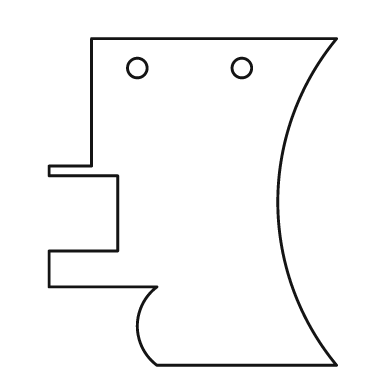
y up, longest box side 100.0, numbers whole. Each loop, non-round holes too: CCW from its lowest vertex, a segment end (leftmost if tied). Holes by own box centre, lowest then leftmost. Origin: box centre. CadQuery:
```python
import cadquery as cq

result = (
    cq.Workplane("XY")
    .moveTo(-11.0, -50.0)
    .lineTo(44.0, -50.0)
    .threePointArc((26.0, 0.0), (44.0, 50.0))
    .lineTo(-31.0, 50.0)
    .lineTo(-31.0, 11.0)
    .lineTo(-44.0, 11.0)
    .lineTo(-44.0, 8.0)
    .lineTo(-23.0, 8.0)
    .lineTo(-23.0, -15.0)
    .lineTo(-44.0, -15.0)
    .lineTo(-44.0, -26.0)
    .lineTo(-11.0, -26.0)
    .threePointArc((-17.0, -38.0), (-11.0, -50.0))
    .close()
    .moveTo(-17.0, 41.0)
    .circle(3.0)
    .moveTo(15.0, 41.0)
    .circle(3.0)
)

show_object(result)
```